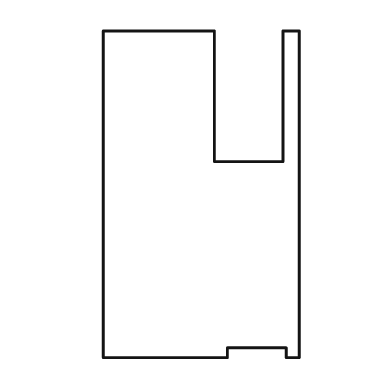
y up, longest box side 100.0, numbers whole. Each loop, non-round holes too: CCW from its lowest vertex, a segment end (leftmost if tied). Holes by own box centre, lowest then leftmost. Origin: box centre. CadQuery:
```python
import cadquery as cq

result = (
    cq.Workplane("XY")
    .moveTo(-30.0, -50.0)
    .lineTo(8.0, -50.0)
    .lineTo(8.0, -47.0)
    .lineTo(26.0, -47.0)
    .lineTo(26.0, -50.0)
    .lineTo(30.0, -50.0)
    .lineTo(30.0, 50.0)
    .lineTo(25.0, 50.0)
    .lineTo(25.0, 10.0)
    .lineTo(4.0, 10.0)
    .lineTo(4.0, 50.0)
    .lineTo(-30.0, 50.0)
    .close()
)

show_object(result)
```